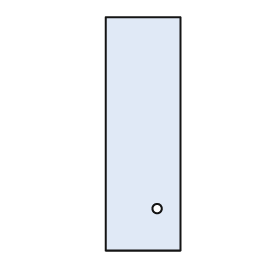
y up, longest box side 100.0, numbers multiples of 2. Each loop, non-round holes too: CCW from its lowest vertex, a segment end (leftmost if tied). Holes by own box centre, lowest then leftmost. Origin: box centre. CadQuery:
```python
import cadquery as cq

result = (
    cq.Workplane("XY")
    .moveTo(-16.0, -50.0)
    .lineTo(16.0, -50.0)
    .lineTo(16.0, 50.0)
    .lineTo(-16.0, 50.0)
    .close()
    .moveTo(6.0, -32.0)
    .circle(2.0)
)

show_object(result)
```